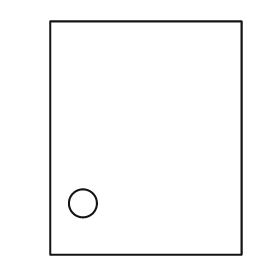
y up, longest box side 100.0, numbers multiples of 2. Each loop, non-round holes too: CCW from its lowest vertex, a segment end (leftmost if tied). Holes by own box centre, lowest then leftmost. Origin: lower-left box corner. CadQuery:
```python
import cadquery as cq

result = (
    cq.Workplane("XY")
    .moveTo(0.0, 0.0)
    .lineTo(82.0, 0.0)
    .lineTo(82.0, 100.0)
    .lineTo(0.0, 100.0)
    .close()
    .moveTo(14.0, 22.0)
    .circle(6.0)
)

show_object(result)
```